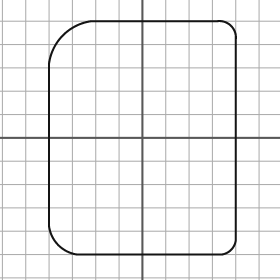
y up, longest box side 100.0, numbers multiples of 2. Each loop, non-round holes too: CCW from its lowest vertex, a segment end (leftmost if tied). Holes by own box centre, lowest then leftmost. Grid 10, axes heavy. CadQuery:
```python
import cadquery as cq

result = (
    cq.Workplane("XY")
    .moveTo(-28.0, -50.0)
    .lineTo(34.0, -50.0)
    .threePointArc((38.0, -48.0), (40.0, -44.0))
    .lineTo(40.0, 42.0)
    .threePointArc((38.0, 48.0), (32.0, 50.0))
    .lineTo(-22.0, 50.0)
    .threePointArc((-34.0, 44.0), (-40.0, 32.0))
    .lineTo(-40.0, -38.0)
    .threePointArc((-36.0, -46.0), (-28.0, -50.0))
    .close()
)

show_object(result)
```